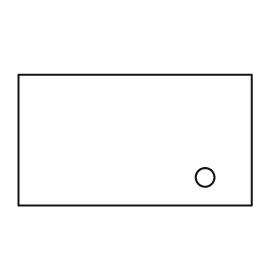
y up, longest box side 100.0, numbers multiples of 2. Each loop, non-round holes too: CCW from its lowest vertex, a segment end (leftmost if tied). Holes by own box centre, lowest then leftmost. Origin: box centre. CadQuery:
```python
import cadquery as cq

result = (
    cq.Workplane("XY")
    .moveTo(-50.0, -28.0)
    .lineTo(50.0, -28.0)
    .lineTo(50.0, 28.0)
    .lineTo(-50.0, 28.0)
    .close()
    .moveTo(30.0, -16.0)
    .circle(4.0)
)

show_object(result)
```